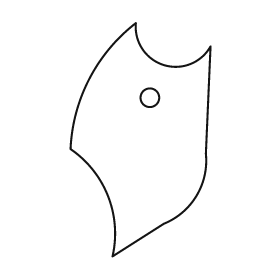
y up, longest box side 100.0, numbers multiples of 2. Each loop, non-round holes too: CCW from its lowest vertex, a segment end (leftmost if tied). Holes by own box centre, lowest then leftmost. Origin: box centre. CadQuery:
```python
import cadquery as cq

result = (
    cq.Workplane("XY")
    .moveTo(-12.0, -50.0)
    .lineTo(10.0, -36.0)
    .threePointArc((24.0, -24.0), (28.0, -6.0))
    .lineTo(30.0, 40.0)
    .threePointArc((10.0, 32.0), (-2.0, 50.0))
    .threePointArc((-22.0, 26.0), (-30.0, -4.0))
    .threePointArc((-14.0, -24.0), (-12.0, -50.0))
    .close()
    .moveTo(4.0, 18.0)
    .circle(4.0)
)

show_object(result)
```